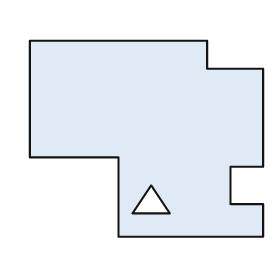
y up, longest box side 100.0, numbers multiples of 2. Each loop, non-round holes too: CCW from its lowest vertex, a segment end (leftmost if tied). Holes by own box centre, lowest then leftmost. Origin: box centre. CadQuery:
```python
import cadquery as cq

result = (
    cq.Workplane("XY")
    .moveTo(-12.0, -42.0)
    .lineTo(50.0, -42.0)
    .lineTo(50.0, -28.0)
    .lineTo(36.0, -28.0)
    .lineTo(36.0, -12.0)
    .lineTo(50.0, -12.0)
    .lineTo(50.0, 30.0)
    .lineTo(26.0, 30.0)
    .lineTo(26.0, 42.0)
    .lineTo(-50.0, 42.0)
    .lineTo(-50.0, -8.0)
    .lineTo(-12.0, -8.0)
    .close()
    .moveTo(-6.0, -32.0)
    .lineTo(10.0, -32.0)
    .lineTo(2.0, -20.0)
    .close()
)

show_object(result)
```